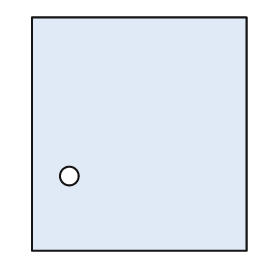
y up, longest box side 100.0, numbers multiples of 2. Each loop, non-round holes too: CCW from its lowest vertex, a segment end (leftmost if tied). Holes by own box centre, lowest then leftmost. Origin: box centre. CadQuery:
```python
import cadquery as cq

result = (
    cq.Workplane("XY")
    .moveTo(-46.0, -50.0)
    .lineTo(46.0, -50.0)
    .lineTo(46.0, 50.0)
    .lineTo(-46.0, 50.0)
    .close()
    .moveTo(-30.0, -18.0)
    .circle(4.0)
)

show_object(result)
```